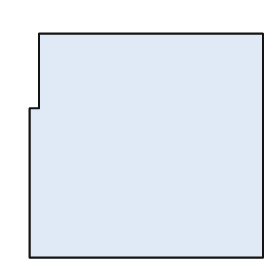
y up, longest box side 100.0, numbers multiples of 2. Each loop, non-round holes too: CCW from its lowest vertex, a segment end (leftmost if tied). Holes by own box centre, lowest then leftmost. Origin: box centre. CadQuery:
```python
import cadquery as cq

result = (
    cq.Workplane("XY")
    .moveTo(-50.0, -48.0)
    .lineTo(50.0, -48.0)
    .lineTo(50.0, 48.0)
    .lineTo(-46.0, 48.0)
    .lineTo(-46.0, 16.0)
    .lineTo(-50.0, 16.0)
    .close()
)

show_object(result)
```